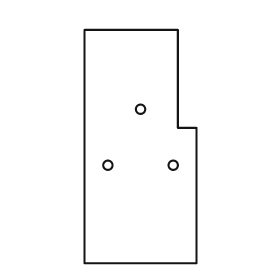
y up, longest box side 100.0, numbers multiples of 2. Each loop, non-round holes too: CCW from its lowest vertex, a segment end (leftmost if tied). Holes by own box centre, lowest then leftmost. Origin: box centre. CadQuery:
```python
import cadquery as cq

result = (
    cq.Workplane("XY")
    .moveTo(-24.0, -50.0)
    .lineTo(24.0, -50.0)
    .lineTo(24.0, 8.0)
    .lineTo(16.0, 8.0)
    .lineTo(16.0, 50.0)
    .lineTo(-24.0, 50.0)
    .close()
    .moveTo(-14.0, -8.0)
    .circle(2.0)
    .moveTo(14.0, -8.0)
    .circle(2.0)
    .moveTo(0.0, 16.0)
    .circle(2.0)
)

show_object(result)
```